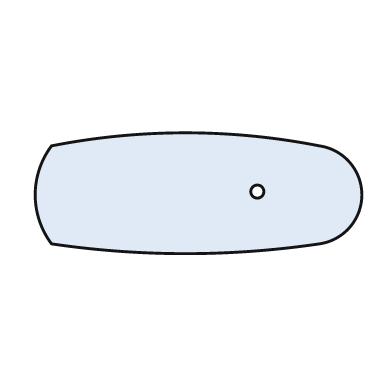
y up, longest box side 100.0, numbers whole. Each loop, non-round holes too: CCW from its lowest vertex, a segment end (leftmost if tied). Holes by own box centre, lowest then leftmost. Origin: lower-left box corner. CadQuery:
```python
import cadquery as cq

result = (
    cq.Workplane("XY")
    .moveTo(5.0, 3.0)
    .threePointArc((46.0, 0.0), (87.0, 3.0))
    .threePointArc((100.0, 18.0), (87.0, 33.0))
    .threePointArc((46.0, 37.0), (5.0, 33.0))
    .threePointArc((0.0, 18.0), (5.0, 3.0))
    .close()
    .moveTo(68.0, 19.0)
    .circle(2.0)
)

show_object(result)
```